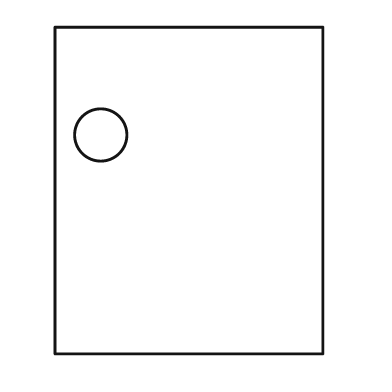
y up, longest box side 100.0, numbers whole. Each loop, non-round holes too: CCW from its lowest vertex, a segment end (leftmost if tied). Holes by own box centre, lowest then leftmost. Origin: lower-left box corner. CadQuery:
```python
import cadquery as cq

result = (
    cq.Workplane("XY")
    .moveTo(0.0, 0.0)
    .lineTo(82.0, 0.0)
    .lineTo(82.0, 100.0)
    .lineTo(0.0, 100.0)
    .close()
    .moveTo(14.0, 67.0)
    .circle(8.0)
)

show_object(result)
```